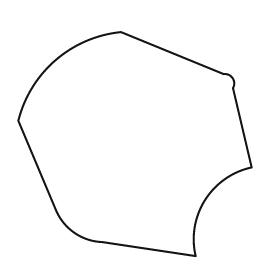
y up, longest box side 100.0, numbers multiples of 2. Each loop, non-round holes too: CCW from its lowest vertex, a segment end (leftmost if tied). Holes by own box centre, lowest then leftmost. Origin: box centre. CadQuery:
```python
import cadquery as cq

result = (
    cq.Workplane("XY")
    .moveTo(26.0, -48.0)
    .threePointArc((30.0, -24.0), (50.0, -10.0))
    .lineTo(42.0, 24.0)
    .threePointArc((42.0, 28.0), (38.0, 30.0))
    .lineTo(-6.0, 48.0)
    .threePointArc((-34.0, 36.0), (-50.0, 10.0))
    .lineTo(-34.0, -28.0)
    .threePointArc((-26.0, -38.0), (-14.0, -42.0))
    .close()
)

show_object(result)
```